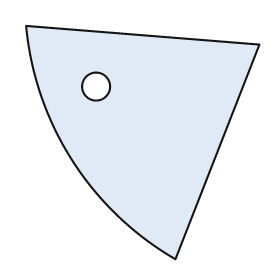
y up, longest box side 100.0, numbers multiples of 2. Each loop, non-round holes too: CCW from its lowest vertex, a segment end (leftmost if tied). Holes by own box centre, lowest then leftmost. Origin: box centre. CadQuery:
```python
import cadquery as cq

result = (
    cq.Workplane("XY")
    .moveTo(14.0, -50.0)
    .lineTo(50.0, 42.0)
    .lineTo(-50.0, 50.0)
    .threePointArc((-30.0, -8.0), (14.0, -50.0))
    .close()
    .moveTo(-20.0, 24.0)
    .circle(6.0)
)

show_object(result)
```